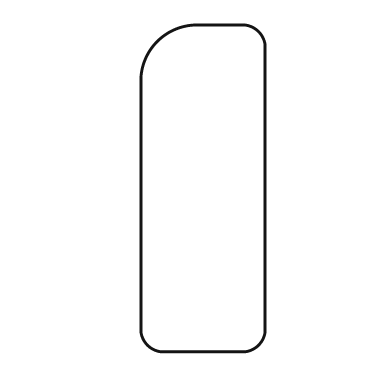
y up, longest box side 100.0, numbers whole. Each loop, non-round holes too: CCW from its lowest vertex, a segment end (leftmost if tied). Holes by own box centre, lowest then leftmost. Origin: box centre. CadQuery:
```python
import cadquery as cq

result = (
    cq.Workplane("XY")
    .moveTo(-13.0, -50.0)
    .lineTo(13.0, -50.0)
    .threePointArc((17.0, -48.0), (19.0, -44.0))
    .lineTo(19.0, 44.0)
    .threePointArc((17.0, 48.0), (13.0, 50.0))
    .lineTo(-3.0, 50.0)
    .threePointArc((-14.0, 45.0), (-19.0, 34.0))
    .lineTo(-19.0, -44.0)
    .threePointArc((-17.0, -48.0), (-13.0, -50.0))
    .close()
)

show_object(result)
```